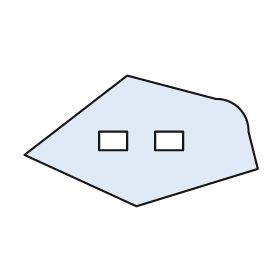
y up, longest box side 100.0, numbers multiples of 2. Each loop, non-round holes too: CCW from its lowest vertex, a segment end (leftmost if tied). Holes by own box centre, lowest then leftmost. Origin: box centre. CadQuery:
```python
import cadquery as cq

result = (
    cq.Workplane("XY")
    .moveTo(-2.0, -28.0)
    .lineTo(50.0, -12.0)
    .lineTo(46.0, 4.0)
    .threePointArc((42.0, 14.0), (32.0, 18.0))
    .lineTo(-6.0, 28.0)
    .lineTo(-50.0, -6.0)
    .close()
    .moveTo(-18.0, -4.0)
    .lineTo(-6.0, -4.0)
    .lineTo(-6.0, 4.0)
    .lineTo(-18.0, 4.0)
    .close()
    .moveTo(6.0, -4.0)
    .lineTo(18.0, -4.0)
    .lineTo(18.0, 4.0)
    .lineTo(6.0, 4.0)
    .close()
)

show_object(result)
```